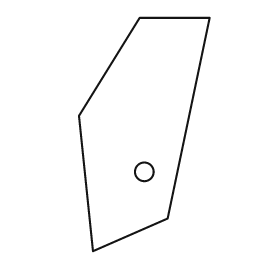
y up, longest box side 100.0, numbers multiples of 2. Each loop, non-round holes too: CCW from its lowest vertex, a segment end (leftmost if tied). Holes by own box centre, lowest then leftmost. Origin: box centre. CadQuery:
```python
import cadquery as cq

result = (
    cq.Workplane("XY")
    .moveTo(-22.0, -50.0)
    .lineTo(10.0, -36.0)
    .lineTo(28.0, 50.0)
    .lineTo(-2.0, 50.0)
    .lineTo(-28.0, 8.0)
    .close()
    .moveTo(0.0, -16.0)
    .circle(4.0)
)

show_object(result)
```